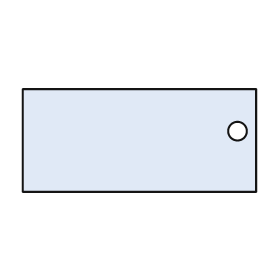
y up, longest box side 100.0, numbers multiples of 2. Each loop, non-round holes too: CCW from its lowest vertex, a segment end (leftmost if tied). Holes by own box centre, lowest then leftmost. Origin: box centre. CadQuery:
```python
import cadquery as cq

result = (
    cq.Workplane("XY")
    .moveTo(-50.0, -22.0)
    .lineTo(50.0, -22.0)
    .lineTo(50.0, 22.0)
    .lineTo(-50.0, 22.0)
    .close()
    .moveTo(42.0, 4.0)
    .circle(4.0)
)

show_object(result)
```